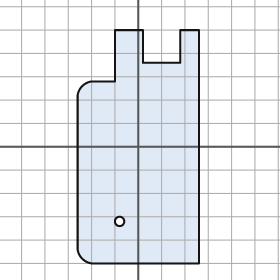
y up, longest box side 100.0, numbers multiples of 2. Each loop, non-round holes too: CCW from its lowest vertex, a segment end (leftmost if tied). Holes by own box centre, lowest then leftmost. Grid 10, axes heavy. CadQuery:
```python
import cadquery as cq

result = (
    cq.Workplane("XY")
    .moveTo(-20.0, -50.0)
    .lineTo(26.0, -50.0)
    .lineTo(26.0, 50.0)
    .lineTo(18.0, 50.0)
    .lineTo(18.0, 36.0)
    .lineTo(2.0, 36.0)
    .lineTo(2.0, 50.0)
    .lineTo(-10.0, 50.0)
    .lineTo(-10.0, 28.0)
    .lineTo(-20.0, 28.0)
    .threePointArc((-24.0, 26.0), (-26.0, 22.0))
    .lineTo(-26.0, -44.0)
    .threePointArc((-24.0, -48.0), (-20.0, -50.0))
    .close()
    .moveTo(-8.0, -32.0)
    .circle(2.0)
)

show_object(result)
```